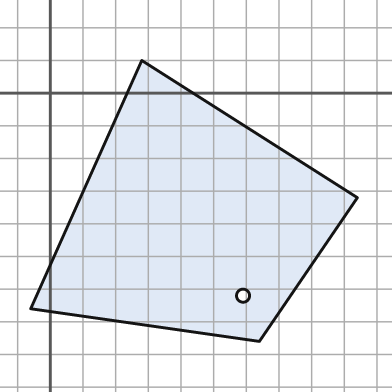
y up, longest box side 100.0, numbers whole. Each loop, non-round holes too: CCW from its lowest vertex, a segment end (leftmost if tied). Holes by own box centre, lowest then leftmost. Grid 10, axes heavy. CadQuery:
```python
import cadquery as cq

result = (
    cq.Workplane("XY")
    .moveTo(64.0, -76.0)
    .lineTo(94.0, -32.0)
    .lineTo(28.0, 10.0)
    .lineTo(-6.0, -66.0)
    .close()
    .moveTo(59.0, -62.0)
    .circle(2.0)
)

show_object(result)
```